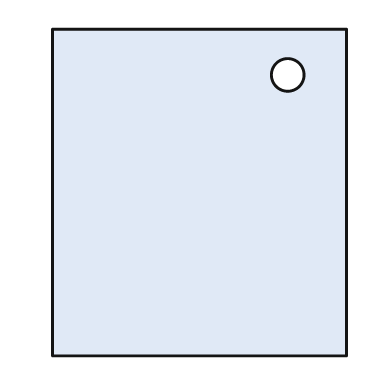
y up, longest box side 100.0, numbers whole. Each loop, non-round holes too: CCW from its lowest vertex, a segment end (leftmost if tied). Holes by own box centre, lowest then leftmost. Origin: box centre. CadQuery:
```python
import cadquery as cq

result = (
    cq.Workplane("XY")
    .moveTo(-45.0, -50.0)
    .lineTo(45.0, -50.0)
    .lineTo(45.0, 50.0)
    .lineTo(-45.0, 50.0)
    .close()
    .moveTo(27.0, 36.0)
    .circle(5.0)
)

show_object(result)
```